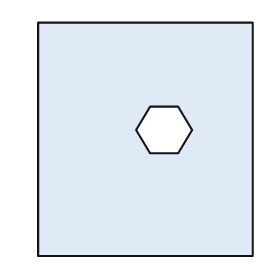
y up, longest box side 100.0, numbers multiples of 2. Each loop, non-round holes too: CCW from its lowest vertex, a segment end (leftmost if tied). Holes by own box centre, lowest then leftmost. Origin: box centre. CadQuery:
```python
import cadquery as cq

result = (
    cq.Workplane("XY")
    .moveTo(-46.0, -50.0)
    .lineTo(46.0, -50.0)
    .lineTo(46.0, 50.0)
    .lineTo(-46.0, 50.0)
    .close()
    .moveTo(2.0, -6.0)
    .lineTo(14.0, -6.0)
    .lineTo(20.0, 4.0)
    .lineTo(14.0, 14.0)
    .lineTo(2.0, 14.0)
    .lineTo(-4.0, 4.0)
    .close()
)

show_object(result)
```